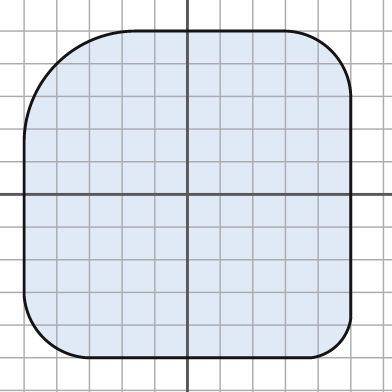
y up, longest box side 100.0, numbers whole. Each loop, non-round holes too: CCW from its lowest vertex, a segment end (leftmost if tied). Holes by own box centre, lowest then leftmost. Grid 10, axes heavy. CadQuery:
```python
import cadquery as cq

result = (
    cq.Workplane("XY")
    .moveTo(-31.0, -50.0)
    .lineTo(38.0, -50.0)
    .threePointArc((46.0, -46.0), (50.0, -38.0))
    .lineTo(50.0, 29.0)
    .threePointArc((44.0, 44.0), (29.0, 50.0))
    .lineTo(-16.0, 50.0)
    .threePointArc((-40.0, 40.0), (-50.0, 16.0))
    .lineTo(-50.0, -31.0)
    .threePointArc((-44.0, -44.0), (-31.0, -50.0))
    .close()
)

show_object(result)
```